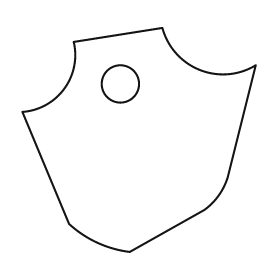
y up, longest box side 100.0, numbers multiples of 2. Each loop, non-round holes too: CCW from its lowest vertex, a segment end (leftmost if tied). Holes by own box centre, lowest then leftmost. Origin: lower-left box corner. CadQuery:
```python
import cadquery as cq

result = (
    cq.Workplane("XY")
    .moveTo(46.0, 0.0)
    .lineTo(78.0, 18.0)
    .threePointArc((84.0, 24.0), (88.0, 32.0))
    .lineTo(100.0, 80.0)
    .threePointArc((76.0, 78.0), (60.0, 96.0))
    .lineTo(22.0, 90.0)
    .threePointArc((18.0, 70.0), (0.0, 60.0))
    .lineTo(20.0, 12.0)
    .threePointArc((32.0, 4.0), (46.0, 0.0))
    .close()
    .moveTo(42.0, 72.0)
    .circle(8.0)
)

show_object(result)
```